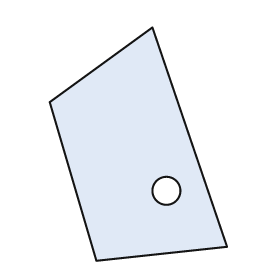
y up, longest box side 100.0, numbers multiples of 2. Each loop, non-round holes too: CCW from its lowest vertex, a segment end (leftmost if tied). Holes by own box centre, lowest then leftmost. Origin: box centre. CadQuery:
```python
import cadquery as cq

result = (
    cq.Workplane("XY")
    .moveTo(-18.0, -50.0)
    .lineTo(38.0, -44.0)
    .lineTo(6.0, 50.0)
    .lineTo(-38.0, 18.0)
    .close()
    .moveTo(12.0, -20.0)
    .circle(6.0)
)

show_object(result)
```